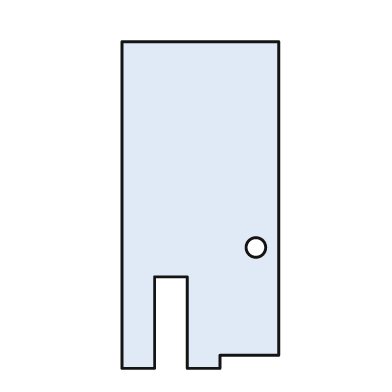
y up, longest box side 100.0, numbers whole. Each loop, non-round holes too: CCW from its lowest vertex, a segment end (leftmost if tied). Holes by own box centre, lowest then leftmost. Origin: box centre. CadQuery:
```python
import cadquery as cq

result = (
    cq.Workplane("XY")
    .moveTo(-24.0, -50.0)
    .lineTo(-14.0, -50.0)
    .lineTo(-14.0, -22.0)
    .lineTo(-4.0, -22.0)
    .lineTo(-4.0, -50.0)
    .lineTo(6.0, -50.0)
    .lineTo(6.0, -46.0)
    .lineTo(24.0, -46.0)
    .lineTo(24.0, 50.0)
    .lineTo(-24.0, 50.0)
    .close()
    .moveTo(17.0, -13.0)
    .circle(3.0)
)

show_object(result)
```